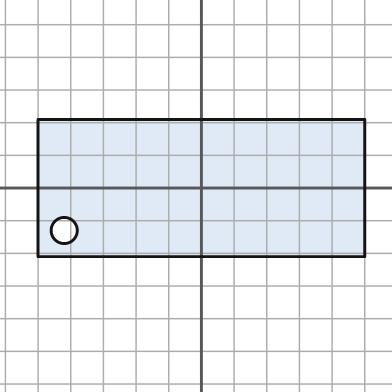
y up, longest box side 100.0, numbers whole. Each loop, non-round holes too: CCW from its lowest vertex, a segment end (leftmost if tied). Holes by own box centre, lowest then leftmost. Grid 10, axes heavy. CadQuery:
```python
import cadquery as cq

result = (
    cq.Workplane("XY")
    .moveTo(-50.0, -21.0)
    .lineTo(50.0, -21.0)
    .lineTo(50.0, 21.0)
    .lineTo(-50.0, 21.0)
    .close()
    .moveTo(-42.0, -13.0)
    .circle(4.0)
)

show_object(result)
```